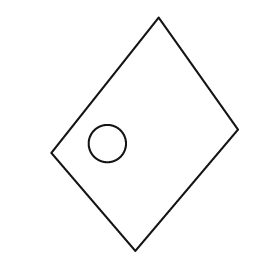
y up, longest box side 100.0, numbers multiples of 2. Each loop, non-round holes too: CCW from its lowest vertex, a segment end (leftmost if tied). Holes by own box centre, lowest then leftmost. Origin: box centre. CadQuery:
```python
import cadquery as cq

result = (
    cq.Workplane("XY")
    .moveTo(-4.0, -50.0)
    .lineTo(40.0, 2.0)
    .lineTo(6.0, 50.0)
    .lineTo(-40.0, -8.0)
    .close()
    .moveTo(-16.0, -4.0)
    .circle(8.0)
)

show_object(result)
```